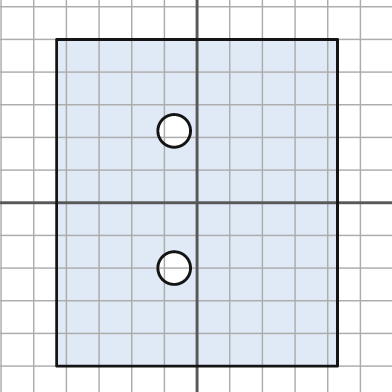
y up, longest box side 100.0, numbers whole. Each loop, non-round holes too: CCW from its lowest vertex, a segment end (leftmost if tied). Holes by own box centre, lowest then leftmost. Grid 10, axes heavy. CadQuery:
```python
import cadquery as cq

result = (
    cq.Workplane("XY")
    .moveTo(-43.0, -50.0)
    .lineTo(43.0, -50.0)
    .lineTo(43.0, 50.0)
    .lineTo(-43.0, 50.0)
    .close()
    .moveTo(-7.0, -20.0)
    .circle(5.0)
    .moveTo(-7.0, 22.0)
    .circle(5.0)
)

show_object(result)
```